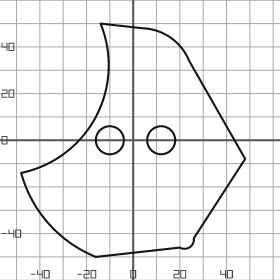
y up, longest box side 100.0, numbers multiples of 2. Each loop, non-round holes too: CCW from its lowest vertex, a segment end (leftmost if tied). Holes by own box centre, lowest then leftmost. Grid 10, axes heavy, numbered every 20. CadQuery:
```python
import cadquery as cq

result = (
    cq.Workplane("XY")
    .moveTo(-16.0, -50.0)
    .lineTo(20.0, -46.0)
    .threePointArc((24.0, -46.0), (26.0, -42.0))
    .lineTo(48.0, -8.0)
    .lineTo(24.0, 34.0)
    .threePointArc((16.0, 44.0), (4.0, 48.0))
    .lineTo(-14.0, 50.0)
    .threePointArc((-16.0, 10.0), (-48.0, -14.0))
    .threePointArc((-36.0, -36.0), (-16.0, -50.0))
    .close()
    .moveTo(-10.0, 0.0)
    .circle(6.0)
    .moveTo(12.0, 0.0)
    .circle(6.0)
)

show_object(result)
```